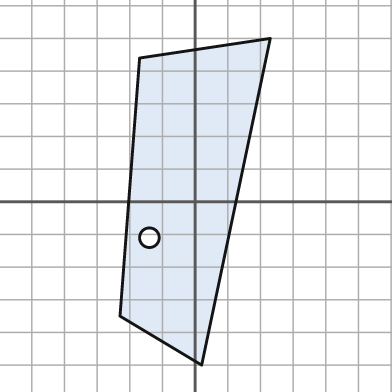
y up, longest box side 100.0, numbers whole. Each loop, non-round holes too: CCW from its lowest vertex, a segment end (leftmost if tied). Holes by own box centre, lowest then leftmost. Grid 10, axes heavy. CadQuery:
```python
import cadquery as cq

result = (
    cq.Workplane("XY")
    .moveTo(2.0, -50.0)
    .lineTo(23.0, 50.0)
    .lineTo(-17.0, 44.0)
    .lineTo(-23.0, -35.0)
    .close()
    .moveTo(-14.0, -11.0)
    .circle(3.0)
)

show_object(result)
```